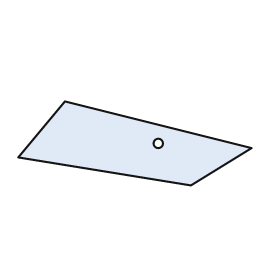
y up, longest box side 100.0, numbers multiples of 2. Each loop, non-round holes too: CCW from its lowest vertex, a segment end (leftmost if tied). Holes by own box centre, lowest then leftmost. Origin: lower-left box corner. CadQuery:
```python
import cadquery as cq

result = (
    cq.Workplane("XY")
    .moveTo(74.0, 0.0)
    .lineTo(100.0, 16.0)
    .lineTo(20.0, 36.0)
    .lineTo(0.0, 12.0)
    .close()
    .moveTo(60.0, 18.0)
    .circle(2.0)
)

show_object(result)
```